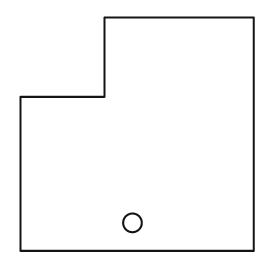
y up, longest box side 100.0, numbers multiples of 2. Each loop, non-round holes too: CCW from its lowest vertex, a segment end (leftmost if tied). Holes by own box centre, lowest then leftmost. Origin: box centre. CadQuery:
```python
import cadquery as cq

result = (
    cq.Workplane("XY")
    .moveTo(-50.0, -50.0)
    .lineTo(50.0, -50.0)
    .lineTo(50.0, 50.0)
    .lineTo(-14.0, 50.0)
    .lineTo(-14.0, 16.0)
    .lineTo(-50.0, 16.0)
    .close()
    .moveTo(-2.0, -38.0)
    .circle(4.0)
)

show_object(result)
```